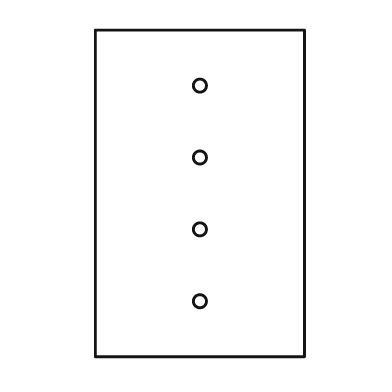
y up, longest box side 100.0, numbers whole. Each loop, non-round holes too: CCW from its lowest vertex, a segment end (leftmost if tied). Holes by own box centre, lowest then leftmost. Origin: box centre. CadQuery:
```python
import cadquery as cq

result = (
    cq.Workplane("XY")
    .moveTo(-32.0, -50.0)
    .lineTo(32.0, -50.0)
    .lineTo(32.0, 50.0)
    .lineTo(-32.0, 50.0)
    .close()
    .moveTo(0.0, -33.0)
    .circle(2.0)
    .moveTo(0.0, -11.0)
    .circle(2.0)
    .moveTo(0.0, 11.0)
    .circle(2.0)
    .moveTo(0.0, 33.0)
    .circle(2.0)
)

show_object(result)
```